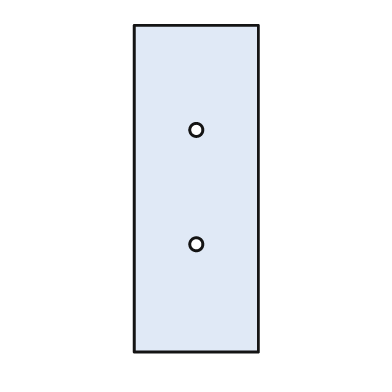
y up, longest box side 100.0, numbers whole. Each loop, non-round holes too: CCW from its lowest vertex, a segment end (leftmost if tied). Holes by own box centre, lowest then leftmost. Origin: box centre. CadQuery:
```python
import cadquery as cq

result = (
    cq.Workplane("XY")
    .moveTo(-19.0, -50.0)
    .lineTo(19.0, -50.0)
    .lineTo(19.0, 50.0)
    .lineTo(-19.0, 50.0)
    .close()
    .moveTo(0.0, -17.0)
    .circle(2.0)
    .moveTo(0.0, 18.0)
    .circle(2.0)
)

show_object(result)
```